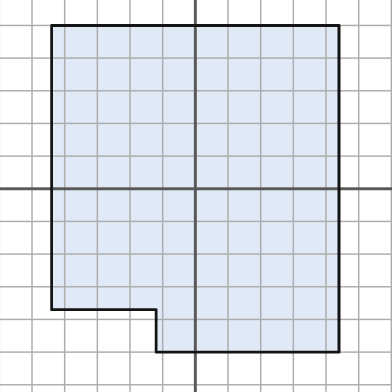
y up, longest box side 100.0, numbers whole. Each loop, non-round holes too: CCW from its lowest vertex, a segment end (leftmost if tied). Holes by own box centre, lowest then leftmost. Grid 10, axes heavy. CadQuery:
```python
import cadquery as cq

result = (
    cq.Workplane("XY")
    .moveTo(-12.0, -50.0)
    .lineTo(44.0, -50.0)
    .lineTo(44.0, 50.0)
    .lineTo(-44.0, 50.0)
    .lineTo(-44.0, -37.0)
    .lineTo(-12.0, -37.0)
    .close()
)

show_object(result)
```